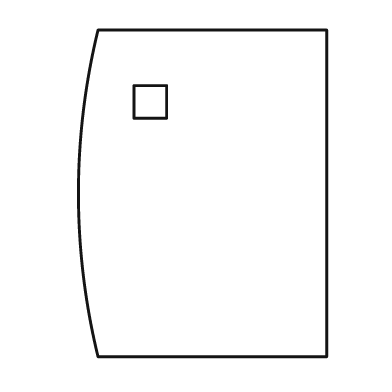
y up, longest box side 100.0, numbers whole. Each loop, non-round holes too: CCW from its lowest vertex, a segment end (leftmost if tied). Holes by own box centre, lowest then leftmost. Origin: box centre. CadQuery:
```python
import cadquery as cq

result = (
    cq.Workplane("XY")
    .moveTo(-32.0, -50.0)
    .lineTo(38.0, -50.0)
    .lineTo(38.0, 50.0)
    .lineTo(-32.0, 50.0)
    .threePointArc((-38.0, 0.0), (-32.0, -50.0))
    .close()
    .moveTo(-21.0, 23.0)
    .lineTo(-11.0, 23.0)
    .lineTo(-11.0, 33.0)
    .lineTo(-21.0, 33.0)
    .close()
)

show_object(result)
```